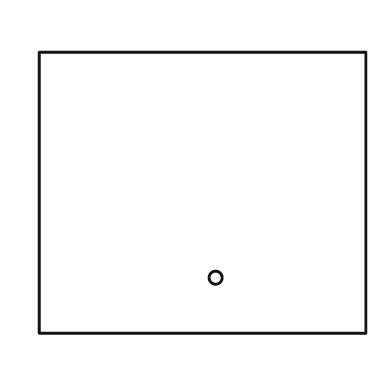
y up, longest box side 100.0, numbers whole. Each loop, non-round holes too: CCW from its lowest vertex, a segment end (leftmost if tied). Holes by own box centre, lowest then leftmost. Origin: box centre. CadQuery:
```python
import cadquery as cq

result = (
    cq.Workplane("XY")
    .moveTo(-50.0, -43.0)
    .lineTo(50.0, -43.0)
    .lineTo(50.0, 43.0)
    .lineTo(-50.0, 43.0)
    .close()
    .moveTo(4.0, -26.0)
    .circle(2.0)
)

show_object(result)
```